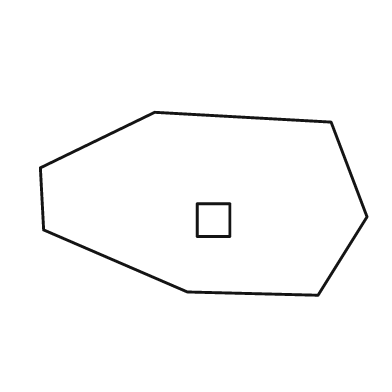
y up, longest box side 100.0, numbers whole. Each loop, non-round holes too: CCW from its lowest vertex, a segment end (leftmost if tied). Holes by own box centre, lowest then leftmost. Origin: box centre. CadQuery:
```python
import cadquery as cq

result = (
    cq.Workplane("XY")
    .moveTo(35.0, -28.0)
    .lineTo(50.0, -4.0)
    .lineTo(39.0, 25.0)
    .lineTo(-15.0, 28.0)
    .lineTo(-50.0, 11.0)
    .lineTo(-49.0, -8.0)
    .lineTo(-5.0, -27.0)
    .close()
    .moveTo(-2.0, -10.0)
    .lineTo(8.0, -10.0)
    .lineTo(8.0, 0.0)
    .lineTo(-2.0, 0.0)
    .close()
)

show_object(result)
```